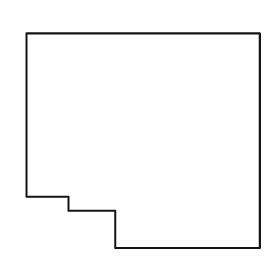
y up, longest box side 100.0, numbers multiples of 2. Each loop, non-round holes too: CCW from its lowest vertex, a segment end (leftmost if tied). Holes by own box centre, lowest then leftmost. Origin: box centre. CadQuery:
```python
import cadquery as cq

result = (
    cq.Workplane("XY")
    .moveTo(-12.0, -46.0)
    .lineTo(50.0, -46.0)
    .lineTo(50.0, 46.0)
    .lineTo(-50.0, 46.0)
    .lineTo(-50.0, -24.0)
    .lineTo(-32.0, -24.0)
    .lineTo(-32.0, -30.0)
    .lineTo(-12.0, -30.0)
    .close()
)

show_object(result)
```